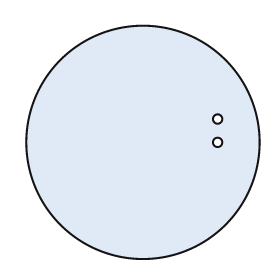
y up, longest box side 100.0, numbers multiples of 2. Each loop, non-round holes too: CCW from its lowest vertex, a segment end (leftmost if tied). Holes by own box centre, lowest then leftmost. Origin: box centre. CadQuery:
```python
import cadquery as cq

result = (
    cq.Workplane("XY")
    .moveTo(0.0, 0.0)
    .circle(50.0)
    .moveTo(32.0, 0.0)
    .circle(2.0)
    .moveTo(32.0, 10.0)
    .circle(2.0)
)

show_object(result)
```